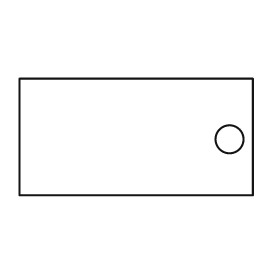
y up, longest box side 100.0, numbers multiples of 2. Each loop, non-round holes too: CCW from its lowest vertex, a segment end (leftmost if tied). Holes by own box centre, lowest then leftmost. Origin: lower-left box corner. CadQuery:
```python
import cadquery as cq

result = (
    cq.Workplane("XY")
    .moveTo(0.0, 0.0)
    .lineTo(100.0, 0.0)
    .lineTo(100.0, 50.0)
    .lineTo(0.0, 50.0)
    .close()
    .moveTo(90.0, 24.0)
    .circle(6.0)
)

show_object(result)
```